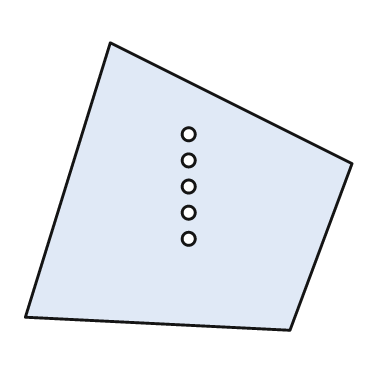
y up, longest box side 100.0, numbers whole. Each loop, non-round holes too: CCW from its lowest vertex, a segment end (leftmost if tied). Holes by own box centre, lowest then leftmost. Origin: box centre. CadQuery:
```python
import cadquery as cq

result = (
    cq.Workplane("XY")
    .moveTo(31.0, -44.0)
    .lineTo(50.0, 7.0)
    .lineTo(-24.0, 44.0)
    .lineTo(-50.0, -40.0)
    .close()
    .moveTo(0.0, -16.0)
    .circle(2.0)
    .moveTo(0.0, -8.0)
    .circle(2.0)
    .moveTo(0.0, 0.0)
    .circle(2.0)
    .moveTo(0.0, 8.0)
    .circle(2.0)
    .moveTo(0.0, 16.0)
    .circle(2.0)
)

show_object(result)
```